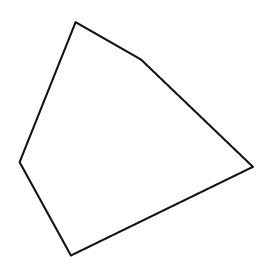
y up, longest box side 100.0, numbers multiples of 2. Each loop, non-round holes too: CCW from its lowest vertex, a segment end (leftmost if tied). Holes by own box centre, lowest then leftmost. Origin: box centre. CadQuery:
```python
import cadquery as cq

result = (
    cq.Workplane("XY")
    .moveTo(-28.0, -50.0)
    .lineTo(50.0, -12.0)
    .lineTo(2.0, 34.0)
    .lineTo(-26.0, 50.0)
    .lineTo(-50.0, -10.0)
    .close()
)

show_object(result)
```